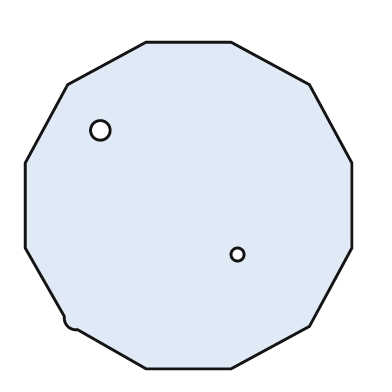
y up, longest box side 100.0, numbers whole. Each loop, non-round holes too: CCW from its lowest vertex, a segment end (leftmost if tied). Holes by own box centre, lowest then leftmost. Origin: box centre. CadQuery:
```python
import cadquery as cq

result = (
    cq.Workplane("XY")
    .moveTo(-13.0, -50.0)
    .lineTo(13.0, -50.0)
    .lineTo(37.0, -37.0)
    .lineTo(50.0, -13.0)
    .lineTo(50.0, 13.0)
    .lineTo(37.0, 37.0)
    .lineTo(13.0, 50.0)
    .lineTo(-13.0, 50.0)
    .lineTo(-37.0, 37.0)
    .lineTo(-50.0, 13.0)
    .lineTo(-50.0, -13.0)
    .lineTo(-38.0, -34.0)
    .threePointArc((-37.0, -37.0), (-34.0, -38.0))
    .close()
    .moveTo(15.0, -15.0)
    .circle(2.0)
    .moveTo(-27.0, 23.0)
    .circle(3.0)
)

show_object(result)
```